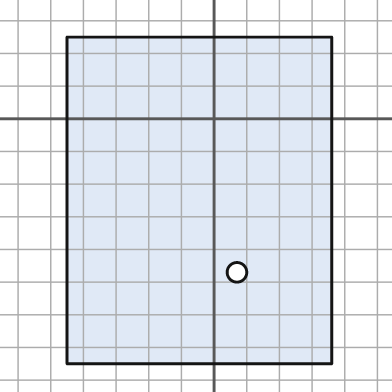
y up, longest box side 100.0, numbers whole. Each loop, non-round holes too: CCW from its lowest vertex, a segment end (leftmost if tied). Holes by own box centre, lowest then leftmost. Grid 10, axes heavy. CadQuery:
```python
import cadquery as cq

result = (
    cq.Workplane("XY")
    .moveTo(-45.0, -75.0)
    .lineTo(36.0, -75.0)
    .lineTo(36.0, 25.0)
    .lineTo(-45.0, 25.0)
    .close()
    .moveTo(7.0, -47.0)
    .circle(3.0)
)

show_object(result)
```